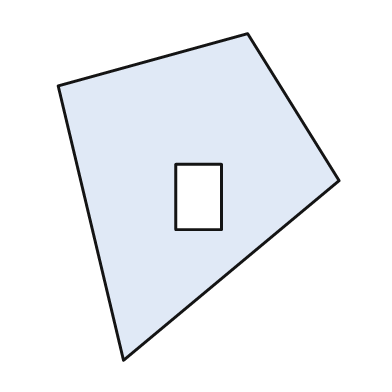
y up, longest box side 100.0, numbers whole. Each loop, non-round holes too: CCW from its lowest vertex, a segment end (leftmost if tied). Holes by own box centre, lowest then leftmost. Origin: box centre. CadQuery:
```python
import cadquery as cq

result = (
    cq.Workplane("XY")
    .moveTo(-23.0, -50.0)
    .lineTo(43.0, 5.0)
    .lineTo(15.0, 50.0)
    .lineTo(-43.0, 34.0)
    .close()
    .moveTo(-7.0, -10.0)
    .lineTo(7.0, -10.0)
    .lineTo(7.0, 10.0)
    .lineTo(-7.0, 10.0)
    .close()
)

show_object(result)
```